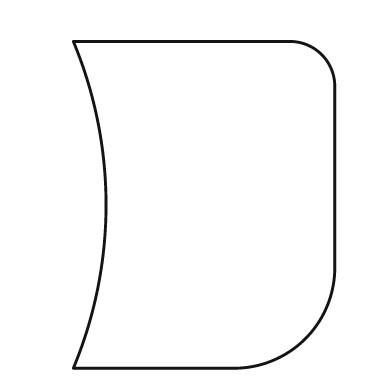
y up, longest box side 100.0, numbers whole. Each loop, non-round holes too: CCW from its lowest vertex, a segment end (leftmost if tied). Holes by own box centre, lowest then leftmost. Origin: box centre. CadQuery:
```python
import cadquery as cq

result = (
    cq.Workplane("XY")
    .moveTo(-40.0, -50.0)
    .lineTo(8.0, -50.0)
    .threePointArc((31.0, -41.0), (40.0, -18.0))
    .lineTo(40.0, 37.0)
    .threePointArc((36.0, 46.0), (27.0, 50.0))
    .lineTo(-40.0, 50.0)
    .threePointArc((-30.0, 0.0), (-40.0, -50.0))
    .close()
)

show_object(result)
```